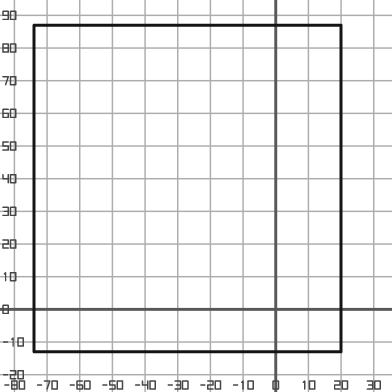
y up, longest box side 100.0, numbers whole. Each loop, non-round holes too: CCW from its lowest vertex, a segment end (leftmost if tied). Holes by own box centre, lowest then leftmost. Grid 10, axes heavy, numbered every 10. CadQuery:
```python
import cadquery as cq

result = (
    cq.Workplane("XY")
    .moveTo(-74.0, -13.0)
    .lineTo(20.0, -13.0)
    .lineTo(20.0, 87.0)
    .lineTo(-74.0, 87.0)
    .close()
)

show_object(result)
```